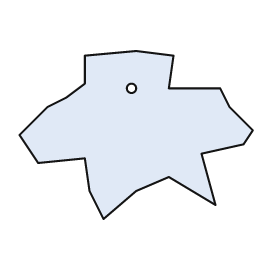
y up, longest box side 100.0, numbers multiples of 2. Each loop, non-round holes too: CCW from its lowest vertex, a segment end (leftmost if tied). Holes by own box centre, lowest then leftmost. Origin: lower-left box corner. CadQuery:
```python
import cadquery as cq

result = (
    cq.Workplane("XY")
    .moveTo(36.0, 0.0)
    .lineTo(50.0, 12.0)
    .lineTo(64.0, 18.0)
    .lineTo(84.0, 6.0)
    .lineTo(78.0, 28.0)
    .lineTo(96.0, 32.0)
    .lineTo(100.0, 38.0)
    .lineTo(90.0, 48.0)
    .lineTo(86.0, 56.0)
    .lineTo(64.0, 56.0)
    .lineTo(66.0, 70.0)
    .lineTo(50.0, 72.0)
    .lineTo(28.0, 70.0)
    .lineTo(28.0, 58.0)
    .lineTo(20.0, 52.0)
    .lineTo(12.0, 48.0)
    .lineTo(0.0, 36.0)
    .lineTo(8.0, 24.0)
    .lineTo(28.0, 26.0)
    .lineTo(30.0, 12.0)
    .close()
    .moveTo(48.0, 56.0)
    .circle(2.0)
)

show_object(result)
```